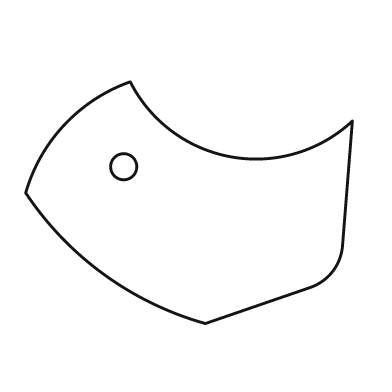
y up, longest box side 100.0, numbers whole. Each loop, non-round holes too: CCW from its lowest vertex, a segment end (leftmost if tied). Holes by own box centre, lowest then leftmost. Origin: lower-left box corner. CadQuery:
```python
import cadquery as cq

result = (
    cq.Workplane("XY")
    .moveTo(55.0, 0.0)
    .lineTo(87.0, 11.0)
    .threePointArc((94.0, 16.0), (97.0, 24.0))
    .lineTo(100.0, 62.0)
    .threePointArc((63.0, 51.0), (32.0, 74.0))
    .threePointArc((12.0, 61.0), (0.0, 40.0))
    .threePointArc((24.0, 15.0), (55.0, 0.0))
    .close()
    .moveTo(30.0, 48.0)
    .circle(4.0)
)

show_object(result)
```